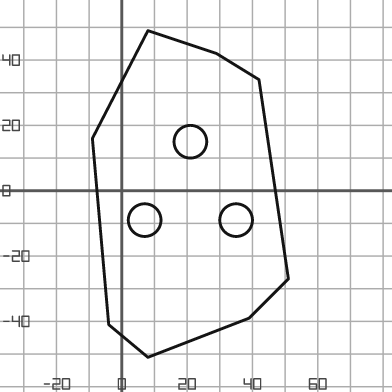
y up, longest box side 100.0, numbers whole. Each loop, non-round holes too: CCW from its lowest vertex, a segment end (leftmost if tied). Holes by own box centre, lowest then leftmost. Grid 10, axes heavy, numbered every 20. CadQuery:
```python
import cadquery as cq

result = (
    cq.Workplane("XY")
    .moveTo(8.0, -51.0)
    .lineTo(39.0, -39.0)
    .lineTo(51.0, -27.0)
    .lineTo(42.0, 34.0)
    .lineTo(29.0, 42.0)
    .lineTo(8.0, 49.0)
    .lineTo(-9.0, 16.0)
    .lineTo(-4.0, -41.0)
    .close()
    .moveTo(7.0, -9.0)
    .circle(5.0)
    .moveTo(35.0, -9.0)
    .circle(5.0)
    .moveTo(21.0, 15.0)
    .circle(5.0)
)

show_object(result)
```